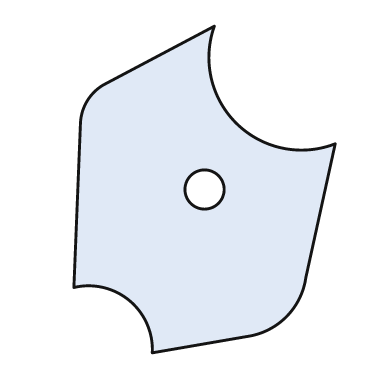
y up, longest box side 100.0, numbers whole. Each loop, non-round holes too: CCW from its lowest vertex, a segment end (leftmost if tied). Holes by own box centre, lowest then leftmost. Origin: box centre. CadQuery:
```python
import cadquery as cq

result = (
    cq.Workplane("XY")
    .moveTo(-16.0, -50.0)
    .lineTo(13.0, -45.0)
    .threePointArc((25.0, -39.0), (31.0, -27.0))
    .lineTo(40.0, 14.0)
    .threePointArc((10.0, 20.0), (3.0, 50.0))
    .lineTo(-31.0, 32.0)
    .threePointArc((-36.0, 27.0), (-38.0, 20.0))
    .lineTo(-40.0, -30.0)
    .threePointArc((-23.0, -34.0), (-16.0, -50.0))
    .close()
    .moveTo(0.0, 0.0)
    .circle(6.0)
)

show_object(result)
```